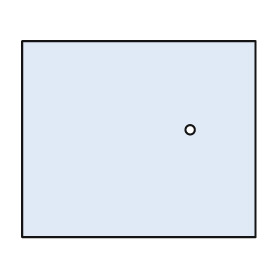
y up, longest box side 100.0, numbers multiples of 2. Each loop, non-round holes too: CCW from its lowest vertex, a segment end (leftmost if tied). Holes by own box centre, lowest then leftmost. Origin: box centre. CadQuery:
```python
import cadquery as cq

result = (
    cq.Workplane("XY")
    .moveTo(-50.0, -42.0)
    .lineTo(50.0, -42.0)
    .lineTo(50.0, 42.0)
    .lineTo(-50.0, 42.0)
    .close()
    .moveTo(22.0, 4.0)
    .circle(2.0)
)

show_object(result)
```